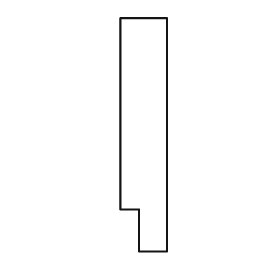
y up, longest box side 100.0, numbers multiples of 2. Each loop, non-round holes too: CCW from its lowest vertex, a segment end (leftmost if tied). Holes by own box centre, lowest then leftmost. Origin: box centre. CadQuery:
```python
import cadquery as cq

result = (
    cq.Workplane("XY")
    .moveTo(-2.0, -50.0)
    .lineTo(10.0, -50.0)
    .lineTo(10.0, 50.0)
    .lineTo(-10.0, 50.0)
    .lineTo(-10.0, -32.0)
    .lineTo(-2.0, -32.0)
    .close()
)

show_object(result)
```